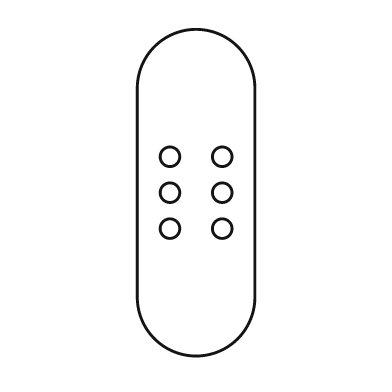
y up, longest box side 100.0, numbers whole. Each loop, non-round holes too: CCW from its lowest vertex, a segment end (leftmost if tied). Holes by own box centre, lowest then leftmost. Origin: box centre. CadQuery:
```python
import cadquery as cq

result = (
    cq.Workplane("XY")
    .moveTo(-18.0, -32.0)
    .threePointArc((0.0, -50.0), (18.0, -32.0))
    .lineTo(18.0, 32.0)
    .threePointArc((0.0, 50.0), (-18.0, 32.0))
    .close()
    .moveTo(-8.0, -11.0)
    .circle(3.0)
    .moveTo(8.0, -11.0)
    .circle(3.0)
    .moveTo(-8.0, 0.0)
    .circle(3.0)
    .moveTo(8.0, 0.0)
    .circle(3.0)
    .moveTo(-8.0, 11.0)
    .circle(3.0)
    .moveTo(8.0, 11.0)
    .circle(3.0)
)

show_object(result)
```